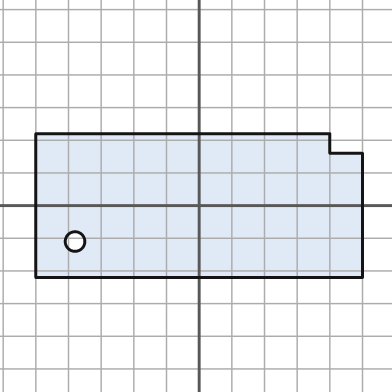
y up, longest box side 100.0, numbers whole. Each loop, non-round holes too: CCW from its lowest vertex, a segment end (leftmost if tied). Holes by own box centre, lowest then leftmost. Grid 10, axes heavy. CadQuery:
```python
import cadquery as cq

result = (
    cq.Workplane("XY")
    .moveTo(-50.0, -22.0)
    .lineTo(50.0, -22.0)
    .lineTo(50.0, 16.0)
    .lineTo(40.0, 16.0)
    .lineTo(40.0, 22.0)
    .lineTo(-50.0, 22.0)
    .close()
    .moveTo(-38.0, -11.0)
    .circle(3.0)
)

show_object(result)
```